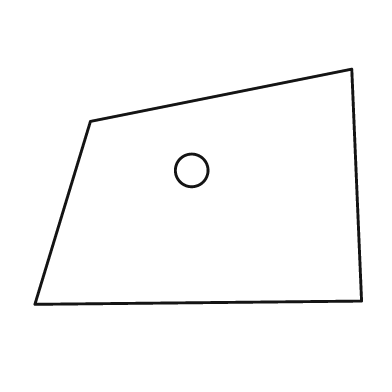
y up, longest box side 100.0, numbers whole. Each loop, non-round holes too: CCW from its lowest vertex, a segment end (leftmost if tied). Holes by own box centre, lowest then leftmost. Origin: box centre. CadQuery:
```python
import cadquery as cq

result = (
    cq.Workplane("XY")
    .moveTo(-50.0, -36.0)
    .lineTo(50.0, -35.0)
    .lineTo(47.0, 36.0)
    .lineTo(-33.0, 20.0)
    .close()
    .moveTo(-2.0, 5.0)
    .circle(5.0)
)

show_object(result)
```